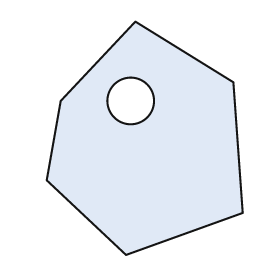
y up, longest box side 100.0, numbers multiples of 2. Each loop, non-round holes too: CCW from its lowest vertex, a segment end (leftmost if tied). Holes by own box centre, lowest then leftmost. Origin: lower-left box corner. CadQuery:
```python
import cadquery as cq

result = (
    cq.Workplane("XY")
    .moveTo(34.0, 0.0)
    .lineTo(84.0, 18.0)
    .lineTo(80.0, 74.0)
    .lineTo(38.0, 100.0)
    .lineTo(6.0, 66.0)
    .lineTo(0.0, 32.0)
    .close()
    .moveTo(36.0, 66.0)
    .circle(10.0)
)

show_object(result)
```